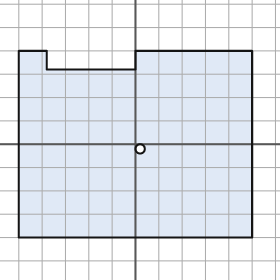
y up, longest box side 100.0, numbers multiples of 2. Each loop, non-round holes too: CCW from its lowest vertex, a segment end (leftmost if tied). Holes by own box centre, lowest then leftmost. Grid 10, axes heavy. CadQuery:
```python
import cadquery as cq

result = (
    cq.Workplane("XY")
    .moveTo(-50.0, -40.0)
    .lineTo(50.0, -40.0)
    .lineTo(50.0, 40.0)
    .lineTo(0.0, 40.0)
    .lineTo(0.0, 32.0)
    .lineTo(-38.0, 32.0)
    .lineTo(-38.0, 40.0)
    .lineTo(-50.0, 40.0)
    .close()
    .moveTo(2.0, -2.0)
    .circle(2.0)
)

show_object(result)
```